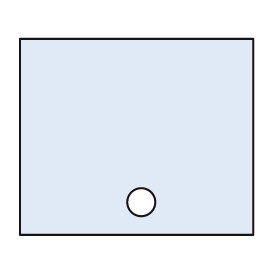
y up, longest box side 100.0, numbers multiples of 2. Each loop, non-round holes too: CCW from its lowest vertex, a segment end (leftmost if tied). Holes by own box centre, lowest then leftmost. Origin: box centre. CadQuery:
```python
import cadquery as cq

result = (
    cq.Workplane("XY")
    .moveTo(-50.0, -42.0)
    .lineTo(50.0, -42.0)
    .lineTo(50.0, 42.0)
    .lineTo(-50.0, 42.0)
    .close()
    .moveTo(2.0, -28.0)
    .circle(6.0)
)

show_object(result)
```